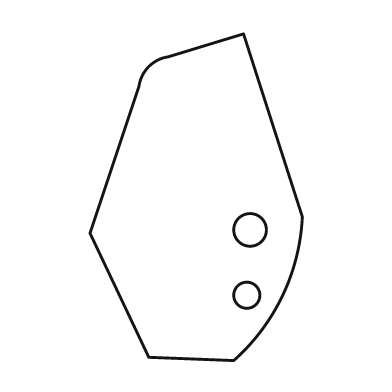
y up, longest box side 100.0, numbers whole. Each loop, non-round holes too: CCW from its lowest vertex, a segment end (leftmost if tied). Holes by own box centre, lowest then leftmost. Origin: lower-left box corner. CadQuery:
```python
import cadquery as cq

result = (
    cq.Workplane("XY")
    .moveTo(44.0, 0.0)
    .threePointArc((59.0, 20.0), (65.0, 44.0))
    .lineTo(47.0, 100.0)
    .lineTo(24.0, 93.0)
    .threePointArc((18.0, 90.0), (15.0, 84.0))
    .lineTo(0.0, 39.0)
    .lineTo(18.0, 1.0)
    .close()
    .moveTo(48.0, 20.0)
    .circle(4.0)
    .moveTo(49.0, 40.0)
    .circle(5.0)
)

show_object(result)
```